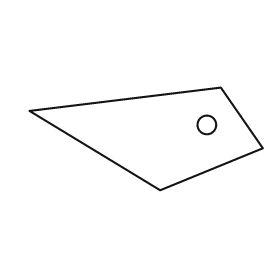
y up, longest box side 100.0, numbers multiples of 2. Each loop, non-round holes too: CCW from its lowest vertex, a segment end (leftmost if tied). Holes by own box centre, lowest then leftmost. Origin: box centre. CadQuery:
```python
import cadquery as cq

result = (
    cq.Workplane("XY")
    .moveTo(6.0, -22.0)
    .lineTo(50.0, -4.0)
    .lineTo(32.0, 22.0)
    .lineTo(-50.0, 12.0)
    .close()
    .moveTo(26.0, 6.0)
    .circle(4.0)
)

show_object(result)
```